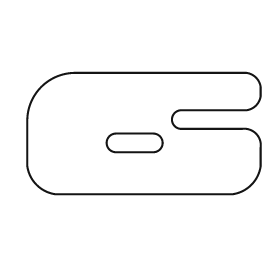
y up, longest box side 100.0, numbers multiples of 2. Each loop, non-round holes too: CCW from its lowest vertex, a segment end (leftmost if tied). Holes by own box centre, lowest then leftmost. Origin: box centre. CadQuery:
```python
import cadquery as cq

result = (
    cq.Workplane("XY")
    .moveTo(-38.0, -26.0)
    .lineTo(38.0, -26.0)
    .threePointArc((46.0, -22.0), (50.0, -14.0))
    .lineTo(50.0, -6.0)
    .threePointArc((48.0, 0.0), (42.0, 2.0))
    .lineTo(16.0, 2.0)
    .threePointArc((12.0, 6.0), (16.0, 10.0))
    .lineTo(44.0, 10.0)
    .threePointArc((48.0, 12.0), (50.0, 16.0))
    .lineTo(50.0, 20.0)
    .threePointArc((48.0, 24.0), (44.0, 26.0))
    .lineTo(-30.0, 26.0)
    .threePointArc((-44.0, 20.0), (-50.0, 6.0))
    .lineTo(-50.0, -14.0)
    .threePointArc((-46.0, -22.0), (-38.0, -26.0))
    .close()
    .moveTo(-12.0, -8.0)
    .lineTo(4.0, -8.0)
    .threePointArc((8.0, -4.0), (4.0, 0.0))
    .lineTo(-12.0, 0.0)
    .threePointArc((-16.0, -4.0), (-12.0, -8.0))
    .close()
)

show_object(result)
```